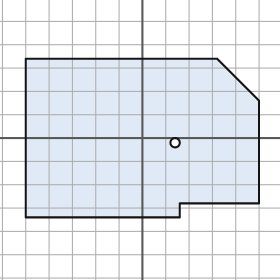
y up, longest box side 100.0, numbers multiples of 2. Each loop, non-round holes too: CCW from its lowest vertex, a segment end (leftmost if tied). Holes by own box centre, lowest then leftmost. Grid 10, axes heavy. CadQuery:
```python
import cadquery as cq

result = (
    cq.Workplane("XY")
    .moveTo(-50.0, -34.0)
    .lineTo(16.0, -34.0)
    .lineTo(16.0, -28.0)
    .lineTo(50.0, -28.0)
    .lineTo(50.0, 16.0)
    .lineTo(32.0, 34.0)
    .lineTo(-50.0, 34.0)
    .close()
    .moveTo(14.0, -2.0)
    .circle(2.0)
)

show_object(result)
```